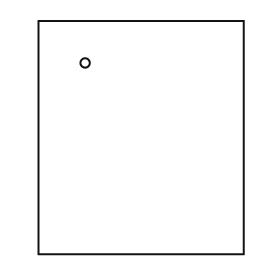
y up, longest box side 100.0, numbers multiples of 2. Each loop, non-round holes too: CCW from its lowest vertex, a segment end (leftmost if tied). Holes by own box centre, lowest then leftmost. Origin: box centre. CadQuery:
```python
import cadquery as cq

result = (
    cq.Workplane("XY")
    .moveTo(-44.0, -50.0)
    .lineTo(44.0, -50.0)
    .lineTo(44.0, 50.0)
    .lineTo(-44.0, 50.0)
    .close()
    .moveTo(-24.0, 32.0)
    .circle(2.0)
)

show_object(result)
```